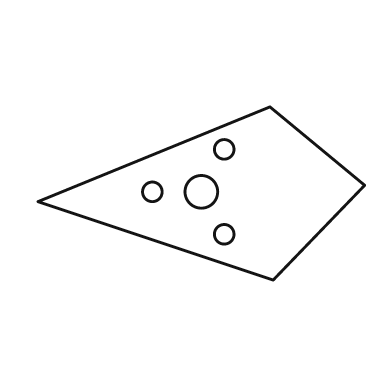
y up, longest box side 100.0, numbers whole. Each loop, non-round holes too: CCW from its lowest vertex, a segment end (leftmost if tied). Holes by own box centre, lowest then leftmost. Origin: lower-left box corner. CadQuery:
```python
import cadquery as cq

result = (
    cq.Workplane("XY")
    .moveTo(72.0, 0.0)
    .lineTo(100.0, 29.0)
    .lineTo(71.0, 53.0)
    .lineTo(0.0, 24.0)
    .close()
    .moveTo(57.0, 14.0)
    .circle(3.0)
    .moveTo(35.0, 27.0)
    .circle(3.0)
    .moveTo(50.0, 27.0)
    .circle(5.0)
    .moveTo(57.0, 40.0)
    .circle(3.0)
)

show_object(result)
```